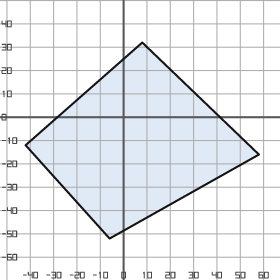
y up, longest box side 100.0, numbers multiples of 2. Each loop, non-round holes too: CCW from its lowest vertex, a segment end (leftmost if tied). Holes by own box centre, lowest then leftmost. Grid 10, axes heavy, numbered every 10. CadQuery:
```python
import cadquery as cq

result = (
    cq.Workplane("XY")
    .moveTo(-6.0, -52.0)
    .lineTo(58.0, -16.0)
    .lineTo(8.0, 32.0)
    .lineTo(-42.0, -12.0)
    .close()
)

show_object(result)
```